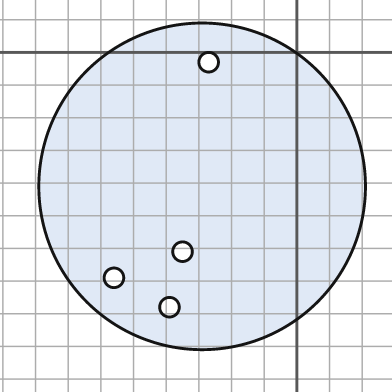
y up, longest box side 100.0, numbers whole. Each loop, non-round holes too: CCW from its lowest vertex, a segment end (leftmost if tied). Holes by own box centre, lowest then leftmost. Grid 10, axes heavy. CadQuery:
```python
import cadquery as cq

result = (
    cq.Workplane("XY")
    .moveTo(-29.0, -41.0)
    .circle(50.0)
    .moveTo(-39.0, -78.0)
    .circle(3.0)
    .moveTo(-56.0, -69.0)
    .circle(3.0)
    .moveTo(-35.0, -61.0)
    .circle(3.0)
    .moveTo(-27.0, -3.0)
    .circle(3.0)
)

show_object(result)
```